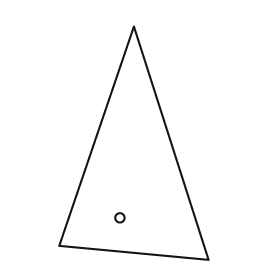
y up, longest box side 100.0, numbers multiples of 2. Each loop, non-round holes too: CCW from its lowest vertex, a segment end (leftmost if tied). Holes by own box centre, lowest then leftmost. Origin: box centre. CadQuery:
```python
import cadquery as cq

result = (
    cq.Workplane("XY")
    .moveTo(32.0, -50.0)
    .lineTo(0.0, 50.0)
    .lineTo(-32.0, -44.0)
    .close()
    .moveTo(-6.0, -32.0)
    .circle(2.0)
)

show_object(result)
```